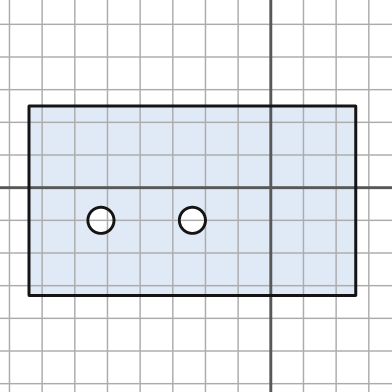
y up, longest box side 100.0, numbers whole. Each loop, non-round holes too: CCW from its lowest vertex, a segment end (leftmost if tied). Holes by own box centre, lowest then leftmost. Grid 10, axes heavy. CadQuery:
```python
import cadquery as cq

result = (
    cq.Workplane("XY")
    .moveTo(-74.0, -33.0)
    .lineTo(26.0, -33.0)
    .lineTo(26.0, 25.0)
    .lineTo(-74.0, 25.0)
    .close()
    .moveTo(-52.0, -10.0)
    .circle(4.0)
    .moveTo(-24.0, -10.0)
    .circle(4.0)
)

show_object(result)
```